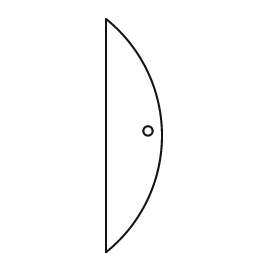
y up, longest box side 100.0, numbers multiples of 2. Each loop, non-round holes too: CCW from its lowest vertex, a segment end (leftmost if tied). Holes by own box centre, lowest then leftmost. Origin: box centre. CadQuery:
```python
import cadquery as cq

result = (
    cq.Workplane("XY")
    .moveTo(-12.0, -50.0)
    .threePointArc((12.0, 0.0), (-12.0, 50.0))
    .close()
    .moveTo(6.0, 2.0)
    .circle(2.0)
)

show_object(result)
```